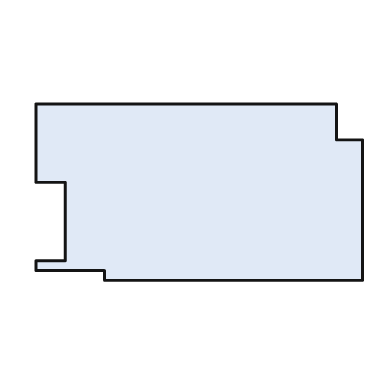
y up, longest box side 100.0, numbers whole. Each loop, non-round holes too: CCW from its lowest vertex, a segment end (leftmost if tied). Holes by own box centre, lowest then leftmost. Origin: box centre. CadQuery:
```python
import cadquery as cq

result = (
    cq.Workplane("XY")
    .moveTo(-29.0, -27.0)
    .lineTo(50.0, -27.0)
    .lineTo(50.0, 16.0)
    .lineTo(42.0, 16.0)
    .lineTo(42.0, 27.0)
    .lineTo(-50.0, 27.0)
    .lineTo(-50.0, 3.0)
    .lineTo(-41.0, 3.0)
    .lineTo(-41.0, -21.0)
    .lineTo(-50.0, -21.0)
    .lineTo(-50.0, -24.0)
    .lineTo(-29.0, -24.0)
    .close()
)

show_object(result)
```